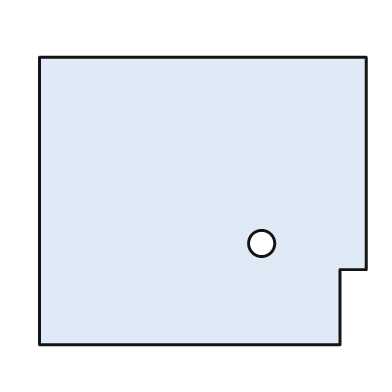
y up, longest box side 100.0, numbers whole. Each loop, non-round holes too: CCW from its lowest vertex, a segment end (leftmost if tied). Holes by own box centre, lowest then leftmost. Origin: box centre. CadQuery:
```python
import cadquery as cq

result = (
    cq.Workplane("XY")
    .moveTo(-50.0, -44.0)
    .lineTo(42.0, -44.0)
    .lineTo(42.0, -21.0)
    .lineTo(50.0, -21.0)
    .lineTo(50.0, 44.0)
    .lineTo(-50.0, 44.0)
    .close()
    .moveTo(18.0, -13.0)
    .circle(4.0)
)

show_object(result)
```